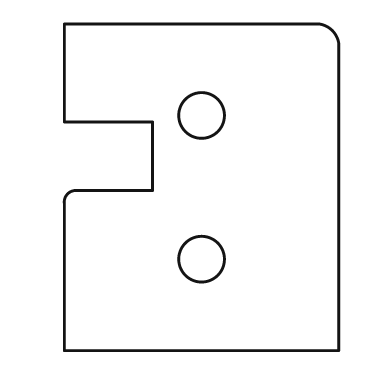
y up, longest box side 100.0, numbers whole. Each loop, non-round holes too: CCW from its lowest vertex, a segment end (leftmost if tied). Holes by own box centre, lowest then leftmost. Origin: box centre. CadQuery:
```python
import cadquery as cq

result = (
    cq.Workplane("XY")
    .moveTo(-42.0, -50.0)
    .lineTo(42.0, -50.0)
    .lineTo(42.0, 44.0)
    .threePointArc((40.0, 48.0), (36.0, 50.0))
    .lineTo(-42.0, 50.0)
    .lineTo(-42.0, 20.0)
    .lineTo(-15.0, 20.0)
    .lineTo(-15.0, -1.0)
    .lineTo(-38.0, -1.0)
    .threePointArc((-41.0, -2.0), (-42.0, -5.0))
    .close()
    .moveTo(0.0, -22.0)
    .circle(7.0)
    .moveTo(0.0, 22.0)
    .circle(7.0)
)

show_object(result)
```